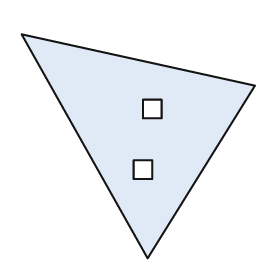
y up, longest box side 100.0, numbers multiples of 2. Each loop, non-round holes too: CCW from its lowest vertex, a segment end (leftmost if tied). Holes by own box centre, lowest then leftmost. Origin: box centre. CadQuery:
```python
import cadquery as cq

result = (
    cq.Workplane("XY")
    .moveTo(4.0, -48.0)
    .lineTo(50.0, 26.0)
    .lineTo(-50.0, 48.0)
    .close()
    .moveTo(-2.0, -14.0)
    .lineTo(6.0, -14.0)
    .lineTo(6.0, -6.0)
    .lineTo(-2.0, -6.0)
    .close()
    .moveTo(2.0, 12.0)
    .lineTo(10.0, 12.0)
    .lineTo(10.0, 20.0)
    .lineTo(2.0, 20.0)
    .close()
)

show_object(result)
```